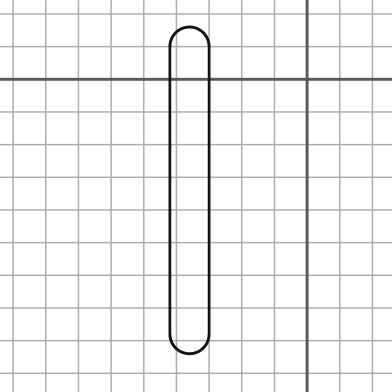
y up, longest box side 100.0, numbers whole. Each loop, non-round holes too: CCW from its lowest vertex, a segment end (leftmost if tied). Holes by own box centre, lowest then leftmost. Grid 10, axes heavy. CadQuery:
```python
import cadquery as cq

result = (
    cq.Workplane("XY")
    .moveTo(-42.0, -78.0)
    .threePointArc((-36.0, -84.0), (-30.0, -78.0))
    .lineTo(-30.0, 10.0)
    .threePointArc((-36.0, 16.0), (-42.0, 10.0))
    .close()
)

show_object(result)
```